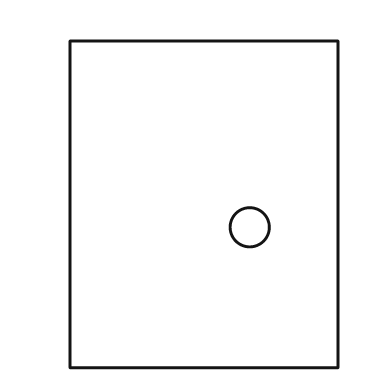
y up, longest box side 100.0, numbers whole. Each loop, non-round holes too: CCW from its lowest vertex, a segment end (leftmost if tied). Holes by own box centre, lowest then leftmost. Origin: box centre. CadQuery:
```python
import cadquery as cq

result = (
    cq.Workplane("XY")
    .moveTo(-41.0, -50.0)
    .lineTo(41.0, -50.0)
    .lineTo(41.0, 50.0)
    .lineTo(-41.0, 50.0)
    .close()
    .moveTo(14.0, -7.0)
    .circle(6.0)
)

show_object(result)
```